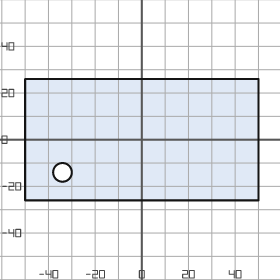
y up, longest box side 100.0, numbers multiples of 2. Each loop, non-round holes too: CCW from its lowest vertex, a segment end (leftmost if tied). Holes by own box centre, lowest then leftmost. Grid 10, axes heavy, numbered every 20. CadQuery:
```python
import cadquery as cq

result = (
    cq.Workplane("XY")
    .moveTo(-50.0, -26.0)
    .lineTo(50.0, -26.0)
    .lineTo(50.0, 26.0)
    .lineTo(-50.0, 26.0)
    .close()
    .moveTo(-34.0, -14.0)
    .circle(4.0)
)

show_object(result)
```